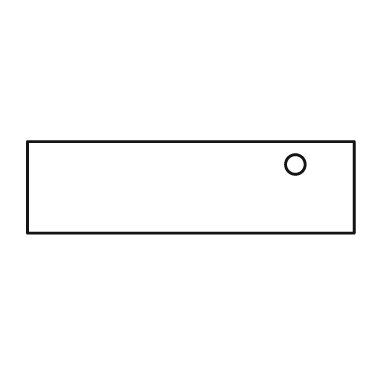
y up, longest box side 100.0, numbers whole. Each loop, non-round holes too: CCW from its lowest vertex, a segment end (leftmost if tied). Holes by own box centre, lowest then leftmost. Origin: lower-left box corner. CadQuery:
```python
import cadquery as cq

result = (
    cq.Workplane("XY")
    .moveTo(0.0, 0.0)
    .lineTo(100.0, 0.0)
    .lineTo(100.0, 28.0)
    .lineTo(0.0, 28.0)
    .close()
    .moveTo(82.0, 21.0)
    .circle(3.0)
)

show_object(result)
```